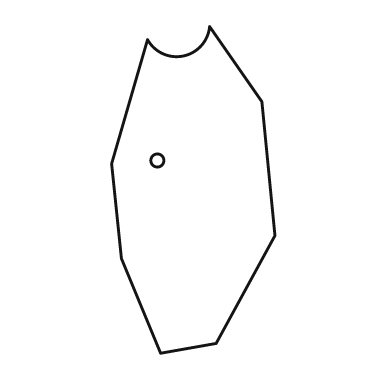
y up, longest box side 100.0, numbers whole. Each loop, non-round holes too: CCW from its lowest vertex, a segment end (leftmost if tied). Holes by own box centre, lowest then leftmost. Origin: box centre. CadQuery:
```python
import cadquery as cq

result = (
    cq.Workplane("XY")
    .moveTo(-10.0, -50.0)
    .lineTo(7.0, -47.0)
    .lineTo(25.0, -14.0)
    .lineTo(21.0, 27.0)
    .lineTo(5.0, 50.0)
    .threePointArc((-3.0, 41.0), (-14.0, 46.0))
    .lineTo(-25.0, 8.0)
    .lineTo(-22.0, -21.0)
    .close()
    .moveTo(-11.0, 9.0)
    .circle(2.0)
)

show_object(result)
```